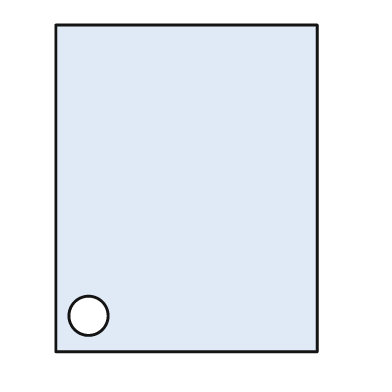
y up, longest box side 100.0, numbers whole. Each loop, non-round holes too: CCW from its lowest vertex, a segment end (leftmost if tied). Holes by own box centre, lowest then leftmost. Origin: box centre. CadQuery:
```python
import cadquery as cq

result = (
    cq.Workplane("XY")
    .moveTo(-40.0, -50.0)
    .lineTo(40.0, -50.0)
    .lineTo(40.0, 50.0)
    .lineTo(-40.0, 50.0)
    .close()
    .moveTo(-30.0, -39.0)
    .circle(6.0)
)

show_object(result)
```